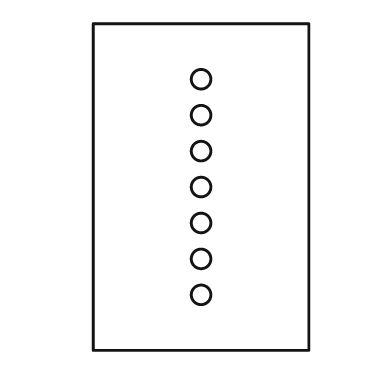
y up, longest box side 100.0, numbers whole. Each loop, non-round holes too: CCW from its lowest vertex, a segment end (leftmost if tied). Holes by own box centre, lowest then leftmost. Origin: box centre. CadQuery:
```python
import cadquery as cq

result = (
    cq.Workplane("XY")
    .moveTo(-33.0, -50.0)
    .lineTo(33.0, -50.0)
    .lineTo(33.0, 50.0)
    .lineTo(-33.0, 50.0)
    .close()
    .moveTo(0.0, -33.0)
    .circle(3.0)
    .moveTo(0.0, -22.0)
    .circle(3.0)
    .moveTo(0.0, -11.0)
    .circle(3.0)
    .moveTo(0.0, 0.0)
    .circle(3.0)
    .moveTo(0.0, 11.0)
    .circle(3.0)
    .moveTo(0.0, 22.0)
    .circle(3.0)
    .moveTo(0.0, 33.0)
    .circle(3.0)
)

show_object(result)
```